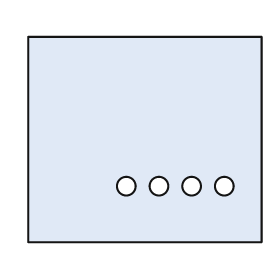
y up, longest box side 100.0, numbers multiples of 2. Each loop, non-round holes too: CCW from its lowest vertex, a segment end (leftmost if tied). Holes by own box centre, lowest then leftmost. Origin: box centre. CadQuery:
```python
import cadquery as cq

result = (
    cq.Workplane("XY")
    .moveTo(-50.0, -44.0)
    .lineTo(50.0, -44.0)
    .lineTo(50.0, 44.0)
    .lineTo(-50.0, 44.0)
    .close()
    .moveTo(-8.0, -20.0)
    .circle(4.0)
    .moveTo(6.0, -20.0)
    .circle(4.0)
    .moveTo(20.0, -20.0)
    .circle(4.0)
    .moveTo(34.0, -20.0)
    .circle(4.0)
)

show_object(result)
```